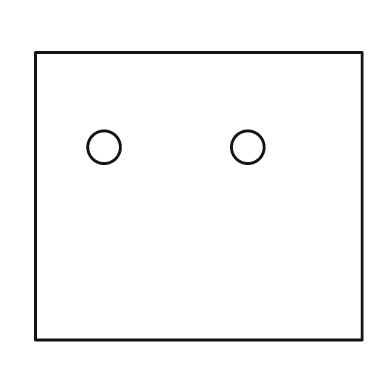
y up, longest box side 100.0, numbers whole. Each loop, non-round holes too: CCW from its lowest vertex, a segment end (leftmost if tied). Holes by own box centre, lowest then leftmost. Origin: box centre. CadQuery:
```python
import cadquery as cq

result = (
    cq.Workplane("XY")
    .moveTo(-50.0, -44.0)
    .lineTo(50.0, -44.0)
    .lineTo(50.0, 44.0)
    .lineTo(-50.0, 44.0)
    .close()
    .moveTo(-29.0, 15.0)
    .circle(5.0)
    .moveTo(15.0, 15.0)
    .circle(5.0)
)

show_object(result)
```